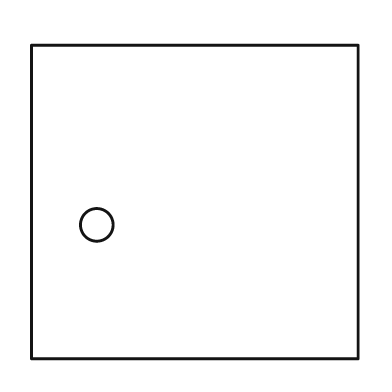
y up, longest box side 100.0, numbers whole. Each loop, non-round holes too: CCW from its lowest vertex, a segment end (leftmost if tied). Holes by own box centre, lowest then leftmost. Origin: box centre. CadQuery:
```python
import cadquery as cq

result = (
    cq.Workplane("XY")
    .moveTo(-50.0, -48.0)
    .lineTo(50.0, -48.0)
    .lineTo(50.0, 48.0)
    .lineTo(-50.0, 48.0)
    .close()
    .moveTo(-30.0, -7.0)
    .circle(5.0)
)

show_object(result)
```